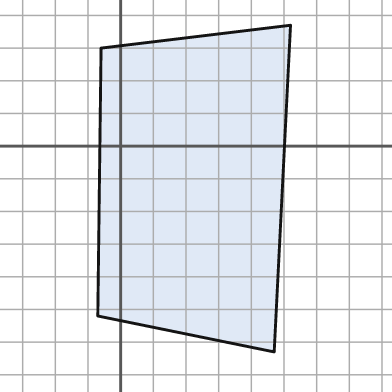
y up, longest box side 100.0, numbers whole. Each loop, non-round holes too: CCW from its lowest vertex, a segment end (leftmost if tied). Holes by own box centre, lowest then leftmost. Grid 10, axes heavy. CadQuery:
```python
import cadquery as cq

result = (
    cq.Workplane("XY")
    .moveTo(47.0, -63.0)
    .lineTo(52.0, 37.0)
    .lineTo(-6.0, 30.0)
    .lineTo(-7.0, -52.0)
    .close()
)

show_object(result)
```